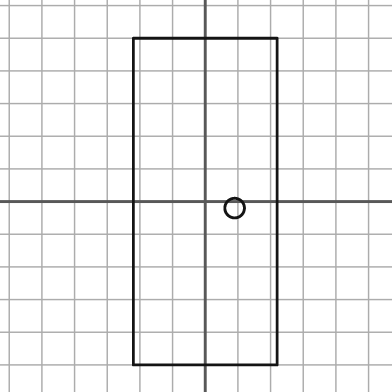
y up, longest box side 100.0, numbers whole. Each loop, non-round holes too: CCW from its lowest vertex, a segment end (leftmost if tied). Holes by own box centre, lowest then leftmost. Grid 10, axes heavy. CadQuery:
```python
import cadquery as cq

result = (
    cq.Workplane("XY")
    .moveTo(-22.0, -50.0)
    .lineTo(22.0, -50.0)
    .lineTo(22.0, 50.0)
    .lineTo(-22.0, 50.0)
    .close()
    .moveTo(9.0, -2.0)
    .circle(3.0)
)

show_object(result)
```